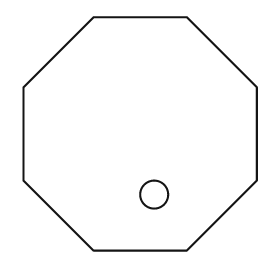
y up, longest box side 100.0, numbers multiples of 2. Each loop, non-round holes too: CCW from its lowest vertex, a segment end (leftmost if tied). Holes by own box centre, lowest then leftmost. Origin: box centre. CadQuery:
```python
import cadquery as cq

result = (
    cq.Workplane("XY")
    .moveTo(-20.0, -50.0)
    .lineTo(20.0, -50.0)
    .lineTo(50.0, -20.0)
    .lineTo(50.0, 20.0)
    .lineTo(20.0, 50.0)
    .lineTo(-20.0, 50.0)
    .lineTo(-50.0, 20.0)
    .lineTo(-50.0, -20.0)
    .close()
    .moveTo(6.0, -26.0)
    .circle(6.0)
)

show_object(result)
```